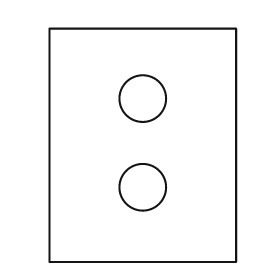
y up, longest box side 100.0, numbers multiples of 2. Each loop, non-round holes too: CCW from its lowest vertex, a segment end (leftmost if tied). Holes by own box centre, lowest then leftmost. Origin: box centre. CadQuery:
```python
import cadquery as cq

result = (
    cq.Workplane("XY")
    .moveTo(-40.0, -50.0)
    .lineTo(40.0, -50.0)
    .lineTo(40.0, 50.0)
    .lineTo(-40.0, 50.0)
    .close()
    .moveTo(0.0, -18.0)
    .circle(10.0)
    .moveTo(0.0, 20.0)
    .circle(10.0)
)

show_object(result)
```